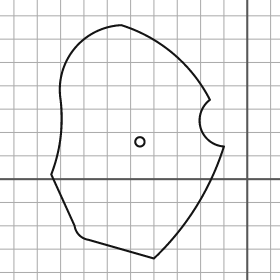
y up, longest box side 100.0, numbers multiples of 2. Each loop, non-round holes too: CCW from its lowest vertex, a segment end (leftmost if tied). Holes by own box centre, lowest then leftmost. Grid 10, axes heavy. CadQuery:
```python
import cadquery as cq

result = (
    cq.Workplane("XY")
    .moveTo(-40.0, -34.0)
    .threePointArc((-22.0, -12.0), (-10.0, 14.0))
    .threePointArc((-20.0, 22.0), (-16.0, 34.0))
    .threePointArc((-32.0, 54.0), (-54.0, 66.0))
    .threePointArc((-74.0, 56.0), (-80.0, 34.0))
    .threePointArc((-80.0, 18.0), (-84.0, 2.0))
    .lineTo(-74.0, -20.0)
    .threePointArc((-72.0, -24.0), (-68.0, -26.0))
    .close()
    .moveTo(-46.0, 16.0)
    .circle(2.0)
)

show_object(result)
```